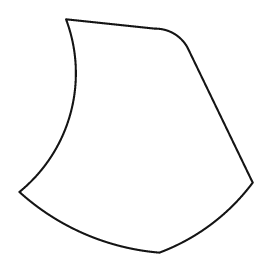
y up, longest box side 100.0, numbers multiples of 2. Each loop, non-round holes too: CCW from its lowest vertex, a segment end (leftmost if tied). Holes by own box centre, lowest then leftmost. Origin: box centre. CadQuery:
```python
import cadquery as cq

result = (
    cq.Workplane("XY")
    .moveTo(10.0, -50.0)
    .threePointArc((32.0, -38.0), (50.0, -20.0))
    .lineTo(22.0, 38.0)
    .threePointArc((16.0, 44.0), (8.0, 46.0))
    .lineTo(-30.0, 50.0)
    .threePointArc((-28.0, 10.0), (-50.0, -24.0))
    .threePointArc((-22.0, -42.0), (10.0, -50.0))
    .close()
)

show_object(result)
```